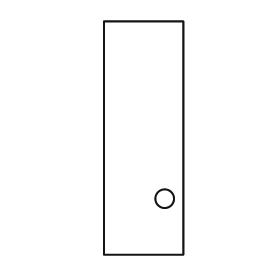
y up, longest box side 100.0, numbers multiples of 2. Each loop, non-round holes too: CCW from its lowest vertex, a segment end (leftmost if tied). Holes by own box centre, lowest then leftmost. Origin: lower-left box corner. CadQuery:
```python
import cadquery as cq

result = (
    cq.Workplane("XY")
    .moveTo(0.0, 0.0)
    .lineTo(34.0, 0.0)
    .lineTo(34.0, 100.0)
    .lineTo(0.0, 100.0)
    .close()
    .moveTo(26.0, 24.0)
    .circle(4.0)
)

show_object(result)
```